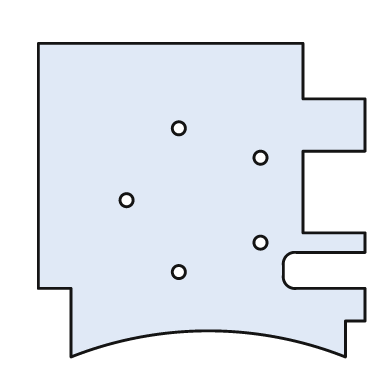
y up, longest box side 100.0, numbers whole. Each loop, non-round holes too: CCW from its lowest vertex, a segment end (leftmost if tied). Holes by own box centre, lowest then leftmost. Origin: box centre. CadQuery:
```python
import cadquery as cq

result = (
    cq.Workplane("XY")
    .moveTo(-40.0, -48.0)
    .threePointArc((2.0, -40.0), (44.0, -48.0))
    .lineTo(44.0, -37.0)
    .lineTo(50.0, -37.0)
    .lineTo(50.0, -27.0)
    .lineTo(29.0, -27.0)
    .threePointArc((26.0, -26.0), (25.0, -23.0))
    .lineTo(25.0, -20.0)
    .threePointArc((26.0, -17.0), (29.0, -16.0))
    .lineTo(50.0, -16.0)
    .lineTo(50.0, -10.0)
    .lineTo(31.0, -10.0)
    .lineTo(31.0, 15.0)
    .lineTo(50.0, 15.0)
    .lineTo(50.0, 31.0)
    .lineTo(31.0, 31.0)
    .lineTo(31.0, 48.0)
    .lineTo(-50.0, 48.0)
    .lineTo(-50.0, -27.0)
    .lineTo(-40.0, -27.0)
    .close()
    .moveTo(-7.0, -22.0)
    .circle(2.0)
    .moveTo(18.0, -13.0)
    .circle(2.0)
    .moveTo(-23.0, 0.0)
    .circle(2.0)
    .moveTo(18.0, 13.0)
    .circle(2.0)
    .moveTo(-7.0, 22.0)
    .circle(2.0)
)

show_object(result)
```